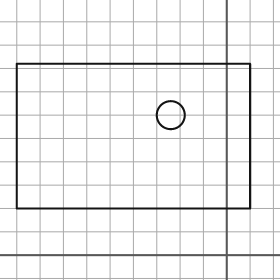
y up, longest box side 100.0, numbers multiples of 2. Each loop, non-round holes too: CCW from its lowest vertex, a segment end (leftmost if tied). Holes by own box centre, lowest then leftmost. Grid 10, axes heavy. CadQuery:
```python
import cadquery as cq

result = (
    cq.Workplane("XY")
    .moveTo(-90.0, 20.0)
    .lineTo(10.0, 20.0)
    .lineTo(10.0, 82.0)
    .lineTo(-90.0, 82.0)
    .close()
    .moveTo(-24.0, 60.0)
    .circle(6.0)
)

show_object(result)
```